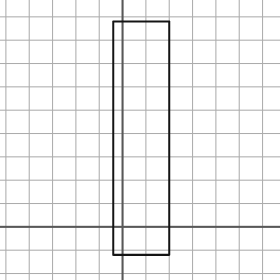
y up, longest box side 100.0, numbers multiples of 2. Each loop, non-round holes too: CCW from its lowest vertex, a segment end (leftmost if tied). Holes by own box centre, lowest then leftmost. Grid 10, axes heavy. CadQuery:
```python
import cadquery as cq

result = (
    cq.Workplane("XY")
    .moveTo(-4.0, -12.0)
    .lineTo(20.0, -12.0)
    .lineTo(20.0, 88.0)
    .lineTo(-4.0, 88.0)
    .close()
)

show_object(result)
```